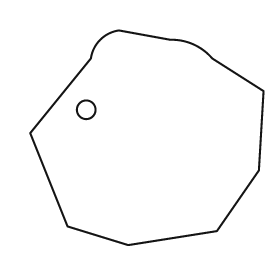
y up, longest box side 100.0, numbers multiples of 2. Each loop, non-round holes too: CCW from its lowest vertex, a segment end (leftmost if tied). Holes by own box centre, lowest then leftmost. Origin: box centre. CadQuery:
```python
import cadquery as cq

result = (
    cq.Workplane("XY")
    .moveTo(-8.0, -46.0)
    .lineTo(30.0, -40.0)
    .lineTo(48.0, -14.0)
    .lineTo(50.0, 20.0)
    .lineTo(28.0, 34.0)
    .threePointArc((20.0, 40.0), (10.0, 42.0))
    .lineTo(-12.0, 46.0)
    .threePointArc((-20.0, 42.0), (-24.0, 34.0))
    .lineTo(-50.0, 2.0)
    .lineTo(-34.0, -38.0)
    .close()
    .moveTo(-26.0, 12.0)
    .circle(4.0)
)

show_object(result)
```